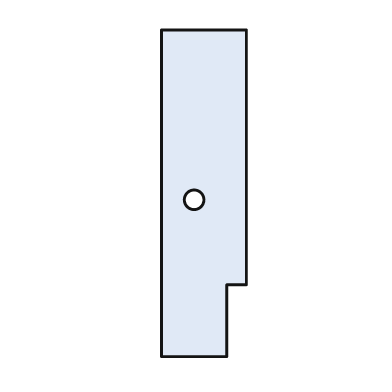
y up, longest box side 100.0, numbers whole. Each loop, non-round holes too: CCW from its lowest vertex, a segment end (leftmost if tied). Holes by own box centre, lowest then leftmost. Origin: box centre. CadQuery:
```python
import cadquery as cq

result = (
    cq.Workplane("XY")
    .moveTo(-13.0, -50.0)
    .lineTo(7.0, -50.0)
    .lineTo(7.0, -28.0)
    .lineTo(13.0, -28.0)
    .lineTo(13.0, 50.0)
    .lineTo(-13.0, 50.0)
    .close()
    .moveTo(-3.0, -2.0)
    .circle(3.0)
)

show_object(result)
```